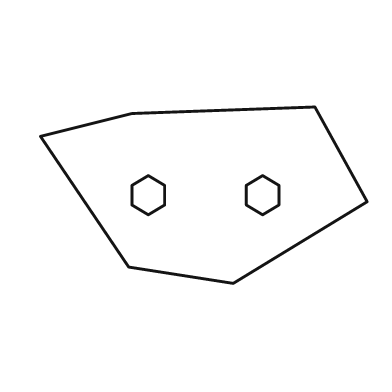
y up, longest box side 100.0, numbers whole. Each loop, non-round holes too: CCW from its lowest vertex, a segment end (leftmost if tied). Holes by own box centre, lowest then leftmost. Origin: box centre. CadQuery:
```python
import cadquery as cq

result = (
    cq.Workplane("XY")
    .moveTo(9.0, -27.0)
    .lineTo(50.0, -2.0)
    .lineTo(34.0, 27.0)
    .lineTo(-22.0, 25.0)
    .lineTo(-50.0, 18.0)
    .lineTo(-23.0, -22.0)
    .close()
    .moveTo(-17.0, -6.0)
    .lineTo(-12.0, -3.0)
    .lineTo(-12.0, 3.0)
    .lineTo(-17.0, 6.0)
    .lineTo(-22.0, 3.0)
    .lineTo(-22.0, -3.0)
    .close()
    .moveTo(18.0, -6.0)
    .lineTo(23.0, -3.0)
    .lineTo(23.0, 3.0)
    .lineTo(18.0, 6.0)
    .lineTo(13.0, 3.0)
    .lineTo(13.0, -3.0)
    .close()
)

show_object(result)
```